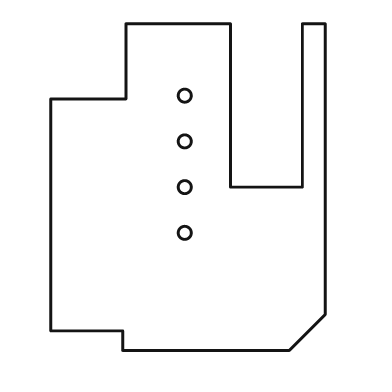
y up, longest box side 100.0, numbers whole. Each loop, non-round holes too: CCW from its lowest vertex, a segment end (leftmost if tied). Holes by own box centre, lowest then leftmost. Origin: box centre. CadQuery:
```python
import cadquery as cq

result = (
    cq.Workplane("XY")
    .moveTo(-20.0, -50.0)
    .lineTo(31.0, -50.0)
    .lineTo(42.0, -39.0)
    .lineTo(42.0, 50.0)
    .lineTo(35.0, 50.0)
    .lineTo(35.0, 0.0)
    .lineTo(13.0, 0.0)
    .lineTo(13.0, 50.0)
    .lineTo(-19.0, 50.0)
    .lineTo(-19.0, 27.0)
    .lineTo(-42.0, 27.0)
    .lineTo(-42.0, -44.0)
    .lineTo(-20.0, -44.0)
    .close()
    .moveTo(-1.0, -14.0)
    .circle(2.0)
    .moveTo(-1.0, 0.0)
    .circle(2.0)
    .moveTo(-1.0, 14.0)
    .circle(2.0)
    .moveTo(-1.0, 28.0)
    .circle(2.0)
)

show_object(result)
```